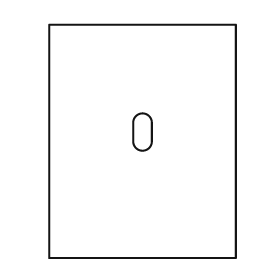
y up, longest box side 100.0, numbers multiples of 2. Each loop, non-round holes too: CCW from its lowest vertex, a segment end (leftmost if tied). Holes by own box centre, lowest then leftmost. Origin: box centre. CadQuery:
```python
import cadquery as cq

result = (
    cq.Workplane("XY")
    .moveTo(-40.0, -50.0)
    .lineTo(40.0, -50.0)
    .lineTo(40.0, 50.0)
    .lineTo(-40.0, 50.0)
    .close()
    .moveTo(-4.0, 0.0)
    .threePointArc((0.0, -4.0), (4.0, 0.0))
    .lineTo(4.0, 8.0)
    .threePointArc((0.0, 12.0), (-4.0, 8.0))
    .close()
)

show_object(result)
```